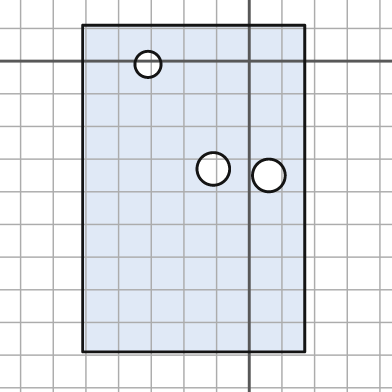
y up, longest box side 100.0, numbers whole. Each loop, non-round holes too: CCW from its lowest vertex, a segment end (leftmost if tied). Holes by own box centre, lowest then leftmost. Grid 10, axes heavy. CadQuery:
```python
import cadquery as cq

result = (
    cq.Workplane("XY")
    .moveTo(-51.0, -89.0)
    .lineTo(17.0, -89.0)
    .lineTo(17.0, 11.0)
    .lineTo(-51.0, 11.0)
    .close()
    .moveTo(6.0, -35.0)
    .circle(5.0)
    .moveTo(-11.0, -33.0)
    .circle(5.0)
    .moveTo(-31.0, -1.0)
    .circle(4.0)
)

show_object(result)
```